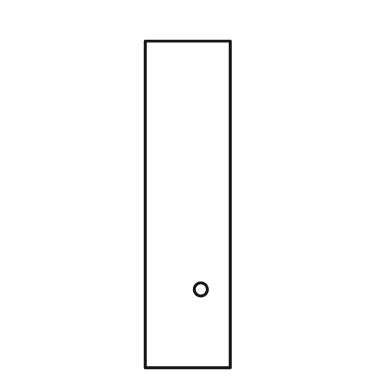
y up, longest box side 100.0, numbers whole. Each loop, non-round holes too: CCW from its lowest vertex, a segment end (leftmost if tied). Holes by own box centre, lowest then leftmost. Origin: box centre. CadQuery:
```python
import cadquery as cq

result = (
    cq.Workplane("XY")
    .moveTo(-13.0, -50.0)
    .lineTo(13.0, -50.0)
    .lineTo(13.0, 50.0)
    .lineTo(-13.0, 50.0)
    .close()
    .moveTo(4.0, -26.0)
    .circle(2.0)
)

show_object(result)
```